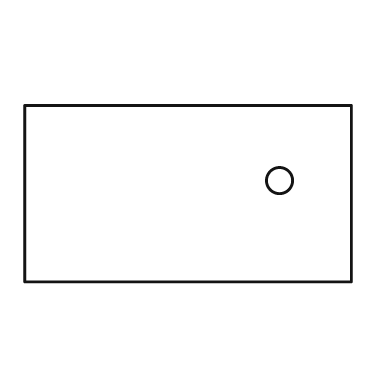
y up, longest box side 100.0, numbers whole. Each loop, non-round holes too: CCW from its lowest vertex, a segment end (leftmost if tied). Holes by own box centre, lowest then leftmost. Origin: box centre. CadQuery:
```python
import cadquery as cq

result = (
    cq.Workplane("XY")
    .moveTo(-50.0, -27.0)
    .lineTo(50.0, -27.0)
    .lineTo(50.0, 27.0)
    .lineTo(-50.0, 27.0)
    .close()
    .moveTo(28.0, 4.0)
    .circle(4.0)
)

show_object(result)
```